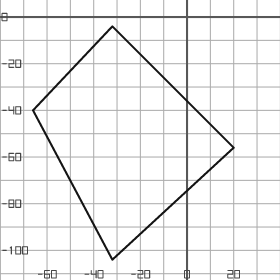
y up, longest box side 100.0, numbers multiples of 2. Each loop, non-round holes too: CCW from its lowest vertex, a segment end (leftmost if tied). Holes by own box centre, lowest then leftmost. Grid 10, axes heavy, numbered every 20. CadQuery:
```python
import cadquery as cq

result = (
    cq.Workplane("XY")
    .moveTo(-32.0, -104.0)
    .lineTo(20.0, -56.0)
    .lineTo(-32.0, -4.0)
    .lineTo(-66.0, -40.0)
    .close()
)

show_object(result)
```